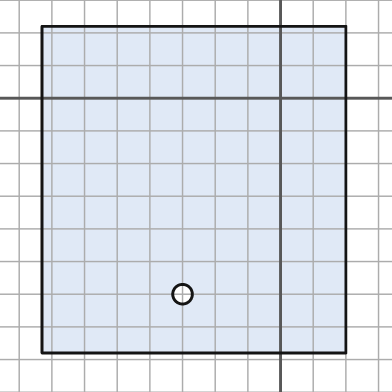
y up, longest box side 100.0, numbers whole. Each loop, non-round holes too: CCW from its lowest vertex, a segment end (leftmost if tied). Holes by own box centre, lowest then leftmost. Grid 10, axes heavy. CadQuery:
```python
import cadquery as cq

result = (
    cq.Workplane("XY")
    .moveTo(-73.0, -78.0)
    .lineTo(20.0, -78.0)
    .lineTo(20.0, 22.0)
    .lineTo(-73.0, 22.0)
    .close()
    .moveTo(-30.0, -60.0)
    .circle(3.0)
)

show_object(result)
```